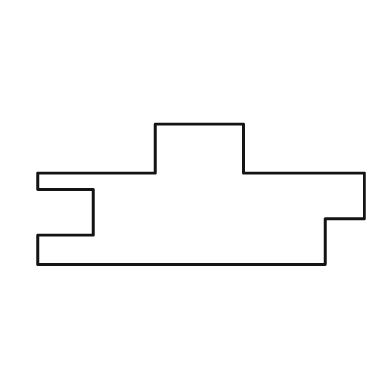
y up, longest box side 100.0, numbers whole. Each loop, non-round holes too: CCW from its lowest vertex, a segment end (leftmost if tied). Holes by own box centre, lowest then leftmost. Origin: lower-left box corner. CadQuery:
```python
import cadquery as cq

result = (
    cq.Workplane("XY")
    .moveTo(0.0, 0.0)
    .lineTo(88.0, 0.0)
    .lineTo(88.0, 14.0)
    .lineTo(100.0, 14.0)
    .lineTo(100.0, 28.0)
    .lineTo(63.0, 28.0)
    .lineTo(63.0, 43.0)
    .lineTo(36.0, 43.0)
    .lineTo(36.0, 28.0)
    .lineTo(0.0, 28.0)
    .lineTo(0.0, 23.0)
    .lineTo(17.0, 23.0)
    .lineTo(17.0, 9.0)
    .lineTo(0.0, 9.0)
    .close()
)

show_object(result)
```